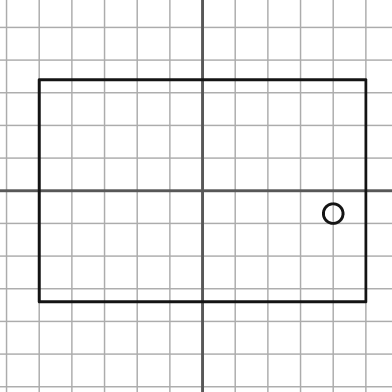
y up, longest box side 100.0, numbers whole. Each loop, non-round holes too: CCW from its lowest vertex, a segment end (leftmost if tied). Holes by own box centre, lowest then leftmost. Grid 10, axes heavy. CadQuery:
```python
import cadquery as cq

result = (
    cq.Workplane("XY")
    .moveTo(-50.0, -34.0)
    .lineTo(50.0, -34.0)
    .lineTo(50.0, 34.0)
    .lineTo(-50.0, 34.0)
    .close()
    .moveTo(40.0, -7.0)
    .circle(3.0)
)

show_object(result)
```